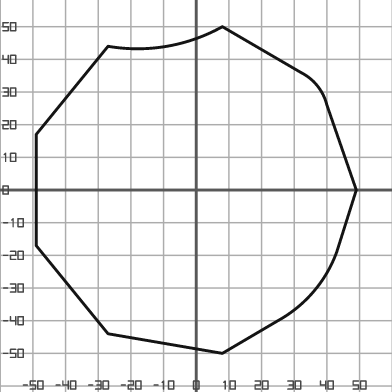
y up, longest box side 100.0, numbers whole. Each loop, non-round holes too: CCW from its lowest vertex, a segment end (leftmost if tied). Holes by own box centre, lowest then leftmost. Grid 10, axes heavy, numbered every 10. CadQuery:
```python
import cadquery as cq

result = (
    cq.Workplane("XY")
    .moveTo(8.0, -50.0)
    .lineTo(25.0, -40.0)
    .threePointArc((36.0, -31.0), (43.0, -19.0))
    .lineTo(49.0, 0.0)
    .lineTo(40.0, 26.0)
    .threePointArc((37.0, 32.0), (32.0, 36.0))
    .lineTo(8.0, 50.0)
    .threePointArc((-9.0, 44.0), (-27.0, 44.0))
    .lineTo(-49.0, 17.0)
    .lineTo(-49.0, -17.0)
    .lineTo(-27.0, -44.0)
    .close()
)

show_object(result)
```